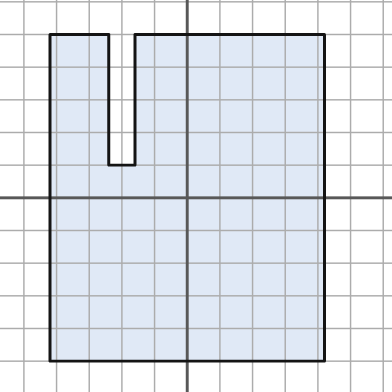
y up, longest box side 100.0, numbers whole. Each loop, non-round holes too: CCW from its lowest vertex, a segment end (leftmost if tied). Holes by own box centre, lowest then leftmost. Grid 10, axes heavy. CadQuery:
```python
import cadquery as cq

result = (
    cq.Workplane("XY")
    .moveTo(-42.0, -50.0)
    .lineTo(42.0, -50.0)
    .lineTo(42.0, 50.0)
    .lineTo(-16.0, 50.0)
    .lineTo(-16.0, 10.0)
    .lineTo(-24.0, 10.0)
    .lineTo(-24.0, 50.0)
    .lineTo(-42.0, 50.0)
    .close()
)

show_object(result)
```